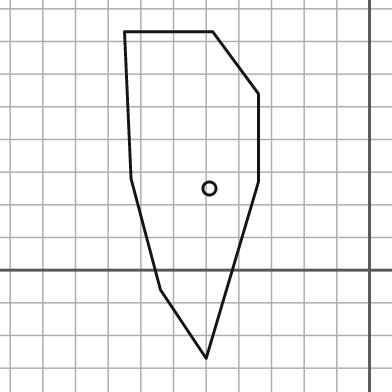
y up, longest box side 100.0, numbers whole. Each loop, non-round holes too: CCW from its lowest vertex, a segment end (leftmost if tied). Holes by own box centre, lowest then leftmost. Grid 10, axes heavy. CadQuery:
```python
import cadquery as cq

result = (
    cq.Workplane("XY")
    .moveTo(-50.0, -27.0)
    .lineTo(-34.0, 27.0)
    .lineTo(-34.0, 54.0)
    .lineTo(-48.0, 73.0)
    .lineTo(-75.0, 73.0)
    .lineTo(-73.0, 28.0)
    .lineTo(-64.0, -6.0)
    .close()
    .moveTo(-49.0, 25.0)
    .circle(2.0)
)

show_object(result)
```